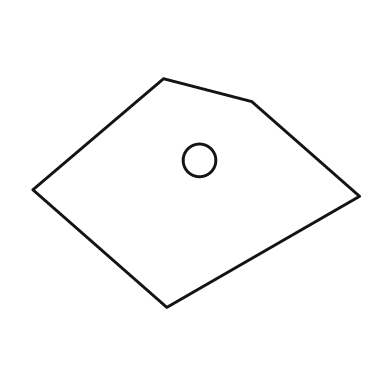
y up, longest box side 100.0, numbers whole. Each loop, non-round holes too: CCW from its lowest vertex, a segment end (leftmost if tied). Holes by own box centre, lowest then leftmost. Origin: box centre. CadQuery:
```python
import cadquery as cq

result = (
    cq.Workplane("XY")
    .moveTo(-9.0, -35.0)
    .lineTo(50.0, -1.0)
    .lineTo(17.0, 28.0)
    .lineTo(-10.0, 35.0)
    .lineTo(-50.0, 1.0)
    .close()
    .moveTo(1.0, 10.0)
    .circle(5.0)
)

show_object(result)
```